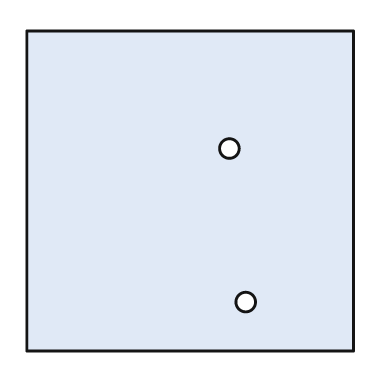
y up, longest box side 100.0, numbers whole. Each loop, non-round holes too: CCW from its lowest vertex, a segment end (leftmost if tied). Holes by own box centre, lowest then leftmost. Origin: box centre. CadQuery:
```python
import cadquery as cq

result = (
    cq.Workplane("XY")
    .moveTo(-50.0, -49.0)
    .lineTo(50.0, -49.0)
    .lineTo(50.0, 49.0)
    .lineTo(-50.0, 49.0)
    .close()
    .moveTo(17.0, -34.0)
    .circle(3.0)
    .moveTo(12.0, 13.0)
    .circle(3.0)
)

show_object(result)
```